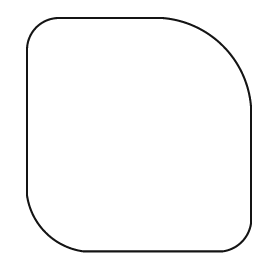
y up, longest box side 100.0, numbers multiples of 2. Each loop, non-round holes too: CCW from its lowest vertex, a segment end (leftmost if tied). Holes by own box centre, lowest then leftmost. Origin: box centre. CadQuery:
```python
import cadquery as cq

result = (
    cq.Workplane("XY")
    .moveTo(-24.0, -50.0)
    .lineTo(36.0, -50.0)
    .threePointArc((44.0, -46.0), (48.0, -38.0))
    .lineTo(48.0, 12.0)
    .threePointArc((36.0, 38.0), (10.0, 50.0))
    .lineTo(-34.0, 50.0)
    .threePointArc((-44.0, 46.0), (-48.0, 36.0))
    .lineTo(-48.0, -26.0)
    .threePointArc((-40.0, -42.0), (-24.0, -50.0))
    .close()
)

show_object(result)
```